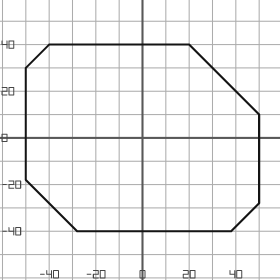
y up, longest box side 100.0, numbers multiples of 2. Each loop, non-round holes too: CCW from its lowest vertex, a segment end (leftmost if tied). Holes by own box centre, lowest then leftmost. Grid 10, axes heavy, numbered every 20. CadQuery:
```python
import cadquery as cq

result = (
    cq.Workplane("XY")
    .moveTo(-28.0, -40.0)
    .lineTo(38.0, -40.0)
    .lineTo(50.0, -28.0)
    .lineTo(50.0, 10.0)
    .lineTo(20.0, 40.0)
    .lineTo(-40.0, 40.0)
    .lineTo(-50.0, 30.0)
    .lineTo(-50.0, -18.0)
    .close()
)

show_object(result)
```